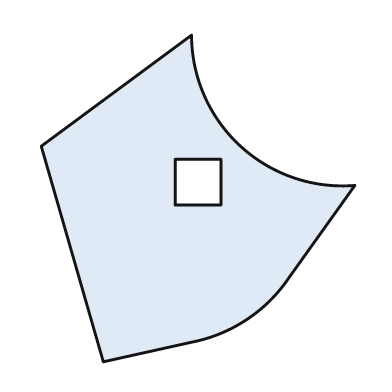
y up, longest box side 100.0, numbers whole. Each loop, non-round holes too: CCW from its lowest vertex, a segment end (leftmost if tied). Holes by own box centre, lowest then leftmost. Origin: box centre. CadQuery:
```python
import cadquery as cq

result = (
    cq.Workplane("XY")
    .moveTo(-29.0, -50.0)
    .lineTo(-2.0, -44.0)
    .threePointArc((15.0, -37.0), (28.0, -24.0))
    .lineTo(48.0, 4.0)
    .threePointArc((13.0, 16.0), (-2.0, 50.0))
    .lineTo(-48.0, 16.0)
    .close()
    .moveTo(-7.0, -2.0)
    .lineTo(7.0, -2.0)
    .lineTo(7.0, 12.0)
    .lineTo(-7.0, 12.0)
    .close()
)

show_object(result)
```